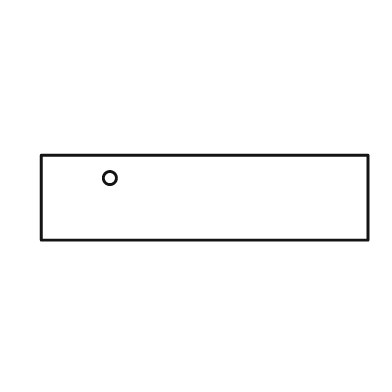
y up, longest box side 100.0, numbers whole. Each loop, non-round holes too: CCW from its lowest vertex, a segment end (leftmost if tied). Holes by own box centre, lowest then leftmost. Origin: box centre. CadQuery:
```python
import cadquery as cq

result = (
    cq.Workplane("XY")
    .moveTo(-50.0, -13.0)
    .lineTo(50.0, -13.0)
    .lineTo(50.0, 13.0)
    .lineTo(-50.0, 13.0)
    .close()
    .moveTo(-29.0, 6.0)
    .circle(2.0)
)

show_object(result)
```